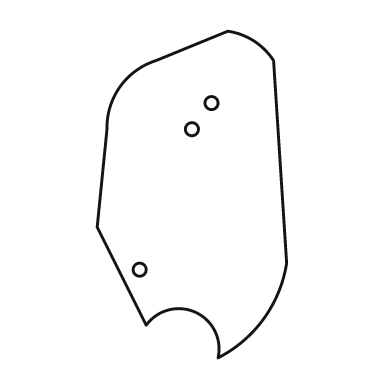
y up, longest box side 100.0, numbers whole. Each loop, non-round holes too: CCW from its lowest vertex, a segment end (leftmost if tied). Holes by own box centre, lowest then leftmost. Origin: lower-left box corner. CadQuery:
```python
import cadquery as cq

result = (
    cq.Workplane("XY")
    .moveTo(37.0, 0.0)
    .threePointArc((51.0, 12.0), (58.0, 29.0))
    .lineTo(54.0, 91.0)
    .threePointArc((48.0, 97.0), (40.0, 100.0))
    .lineTo(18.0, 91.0)
    .threePointArc((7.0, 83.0), (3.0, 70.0))
    .lineTo(0.0, 40.0)
    .lineTo(15.0, 10.0)
    .threePointArc((30.0, 14.0), (37.0, 0.0))
    .close()
    .moveTo(13.0, 27.0)
    .circle(2.0)
    .moveTo(29.0, 70.0)
    .circle(2.0)
    .moveTo(35.0, 78.0)
    .circle(2.0)
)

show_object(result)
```